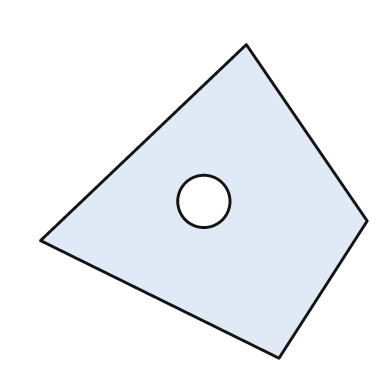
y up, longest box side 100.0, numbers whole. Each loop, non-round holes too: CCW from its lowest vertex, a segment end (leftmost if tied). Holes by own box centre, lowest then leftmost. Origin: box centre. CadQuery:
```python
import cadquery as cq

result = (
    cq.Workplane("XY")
    .moveTo(23.0, -48.0)
    .lineTo(50.0, -6.0)
    .lineTo(13.0, 48.0)
    .lineTo(-50.0, -12.0)
    .close()
    .moveTo(0.0, 0.0)
    .circle(8.0)
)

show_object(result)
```